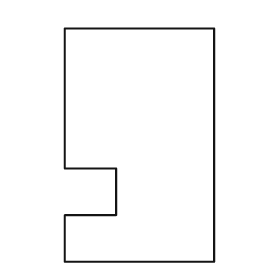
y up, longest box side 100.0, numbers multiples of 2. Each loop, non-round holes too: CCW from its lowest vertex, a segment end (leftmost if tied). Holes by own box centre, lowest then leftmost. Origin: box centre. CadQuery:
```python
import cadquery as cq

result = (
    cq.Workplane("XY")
    .moveTo(-32.0, -50.0)
    .lineTo(32.0, -50.0)
    .lineTo(32.0, 50.0)
    .lineTo(-32.0, 50.0)
    .lineTo(-32.0, -10.0)
    .lineTo(-10.0, -10.0)
    .lineTo(-10.0, -30.0)
    .lineTo(-32.0, -30.0)
    .close()
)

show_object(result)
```